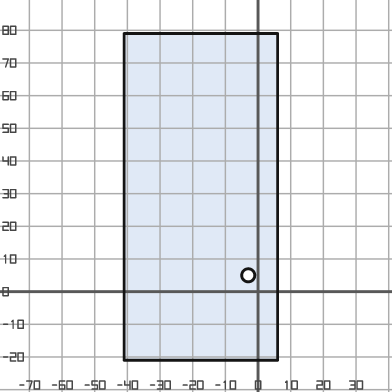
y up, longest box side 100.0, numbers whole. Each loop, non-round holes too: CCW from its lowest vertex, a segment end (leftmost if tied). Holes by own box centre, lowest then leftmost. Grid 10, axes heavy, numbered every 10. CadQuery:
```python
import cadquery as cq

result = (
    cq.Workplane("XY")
    .moveTo(-41.0, -21.0)
    .lineTo(6.0, -21.0)
    .lineTo(6.0, 79.0)
    .lineTo(-41.0, 79.0)
    .close()
    .moveTo(-3.0, 5.0)
    .circle(2.0)
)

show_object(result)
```